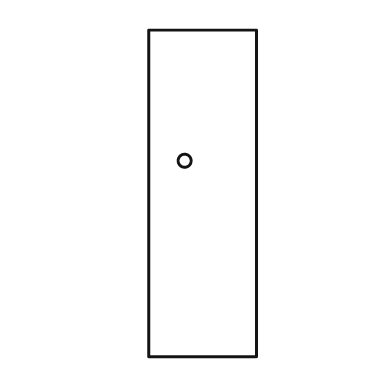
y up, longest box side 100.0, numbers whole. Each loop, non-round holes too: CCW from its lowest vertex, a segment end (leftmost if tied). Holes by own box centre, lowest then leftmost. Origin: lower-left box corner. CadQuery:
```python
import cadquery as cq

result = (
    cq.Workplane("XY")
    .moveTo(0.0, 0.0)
    .lineTo(33.0, 0.0)
    .lineTo(33.0, 100.0)
    .lineTo(0.0, 100.0)
    .close()
    .moveTo(11.0, 60.0)
    .circle(2.0)
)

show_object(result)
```